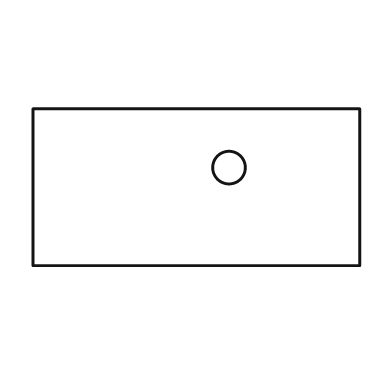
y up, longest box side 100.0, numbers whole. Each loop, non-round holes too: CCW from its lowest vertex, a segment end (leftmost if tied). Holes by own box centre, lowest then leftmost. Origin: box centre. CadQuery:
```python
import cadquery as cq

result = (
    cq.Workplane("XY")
    .moveTo(-50.0, -24.0)
    .lineTo(50.0, -24.0)
    .lineTo(50.0, 24.0)
    .lineTo(-50.0, 24.0)
    .close()
    .moveTo(10.0, 6.0)
    .circle(5.0)
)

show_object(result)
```